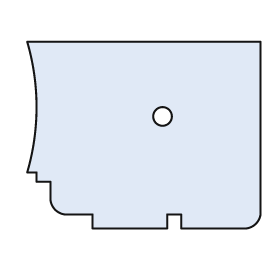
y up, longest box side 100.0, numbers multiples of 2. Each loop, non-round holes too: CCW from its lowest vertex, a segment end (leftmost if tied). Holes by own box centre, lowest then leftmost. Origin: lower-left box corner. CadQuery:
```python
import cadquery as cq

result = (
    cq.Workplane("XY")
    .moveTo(28.0, 0.0)
    .lineTo(60.0, 0.0)
    .lineTo(60.0, 6.0)
    .lineTo(66.0, 6.0)
    .lineTo(66.0, 0.0)
    .lineTo(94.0, 0.0)
    .threePointArc((98.0, 2.0), (100.0, 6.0))
    .lineTo(100.0, 80.0)
    .lineTo(0.0, 80.0)
    .threePointArc((4.0, 52.0), (0.0, 24.0))
    .lineTo(4.0, 24.0)
    .lineTo(4.0, 20.0)
    .lineTo(10.0, 20.0)
    .lineTo(10.0, 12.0)
    .threePointArc((12.0, 8.0), (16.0, 6.0))
    .lineTo(28.0, 6.0)
    .close()
    .moveTo(58.0, 48.0)
    .circle(4.0)
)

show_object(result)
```